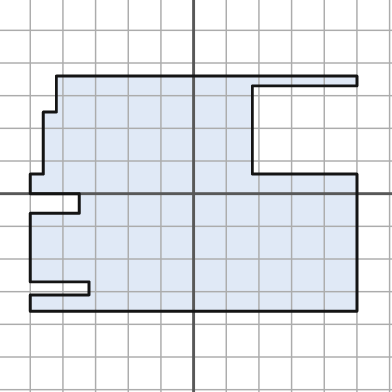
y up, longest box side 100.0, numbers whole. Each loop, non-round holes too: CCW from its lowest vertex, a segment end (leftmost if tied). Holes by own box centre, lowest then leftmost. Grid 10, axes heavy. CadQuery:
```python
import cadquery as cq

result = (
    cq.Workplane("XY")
    .moveTo(-50.0, -36.0)
    .lineTo(50.0, -36.0)
    .lineTo(50.0, 6.0)
    .lineTo(18.0, 6.0)
    .lineTo(18.0, 33.0)
    .lineTo(50.0, 33.0)
    .lineTo(50.0, 36.0)
    .lineTo(-42.0, 36.0)
    .lineTo(-42.0, 25.0)
    .lineTo(-46.0, 25.0)
    .lineTo(-46.0, 6.0)
    .lineTo(-50.0, 6.0)
    .lineTo(-50.0, 0.0)
    .lineTo(-35.0, 0.0)
    .lineTo(-35.0, -6.0)
    .lineTo(-50.0, -6.0)
    .lineTo(-50.0, -27.0)
    .lineTo(-32.0, -27.0)
    .lineTo(-32.0, -31.0)
    .lineTo(-50.0, -31.0)
    .close()
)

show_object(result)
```